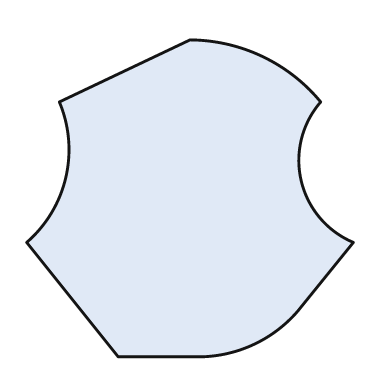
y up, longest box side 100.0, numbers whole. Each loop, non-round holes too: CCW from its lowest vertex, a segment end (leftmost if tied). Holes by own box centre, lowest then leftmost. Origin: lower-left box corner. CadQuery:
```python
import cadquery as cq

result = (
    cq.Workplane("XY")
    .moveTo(28.0, 0.0)
    .lineTo(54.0, 0.0)
    .threePointArc((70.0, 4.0), (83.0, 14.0))
    .lineTo(100.0, 35.0)
    .threePointArc((84.0, 54.0), (90.0, 78.0))
    .threePointArc((72.0, 92.0), (50.0, 97.0))
    .lineTo(10.0, 78.0)
    .threePointArc((12.0, 55.0), (0.0, 35.0))
    .close()
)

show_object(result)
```